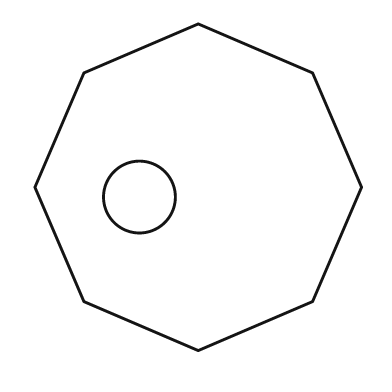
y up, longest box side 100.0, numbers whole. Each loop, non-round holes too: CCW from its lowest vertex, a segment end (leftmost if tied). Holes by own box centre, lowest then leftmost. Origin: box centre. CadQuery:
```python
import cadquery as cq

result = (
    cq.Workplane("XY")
    .moveTo(0.0, -50.0)
    .lineTo(35.0, -35.0)
    .lineTo(50.0, 0.0)
    .lineTo(35.0, 35.0)
    .lineTo(0.0, 50.0)
    .lineTo(-35.0, 35.0)
    .lineTo(-50.0, 0.0)
    .lineTo(-35.0, -35.0)
    .close()
    .moveTo(-18.0, -3.0)
    .circle(11.0)
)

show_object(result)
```